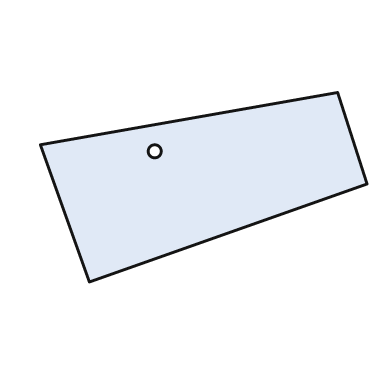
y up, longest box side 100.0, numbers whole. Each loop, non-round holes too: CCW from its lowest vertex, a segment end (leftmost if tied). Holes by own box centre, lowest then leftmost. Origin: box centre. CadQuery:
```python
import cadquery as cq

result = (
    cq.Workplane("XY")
    .moveTo(-35.0, -29.0)
    .lineTo(50.0, 1.0)
    .lineTo(41.0, 29.0)
    .lineTo(-50.0, 13.0)
    .close()
    .moveTo(-15.0, 11.0)
    .circle(2.0)
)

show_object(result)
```